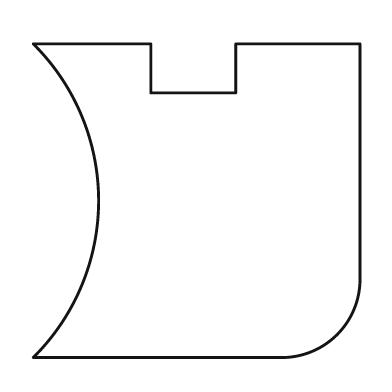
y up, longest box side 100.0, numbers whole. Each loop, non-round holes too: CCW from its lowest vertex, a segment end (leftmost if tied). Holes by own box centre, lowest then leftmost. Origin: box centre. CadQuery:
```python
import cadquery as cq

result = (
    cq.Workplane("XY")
    .moveTo(-50.0, -48.0)
    .lineTo(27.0, -48.0)
    .threePointArc((43.0, -41.0), (50.0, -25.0))
    .lineTo(50.0, 48.0)
    .lineTo(12.0, 48.0)
    .lineTo(12.0, 33.0)
    .lineTo(-14.0, 33.0)
    .lineTo(-14.0, 48.0)
    .lineTo(-50.0, 48.0)
    .threePointArc((-30.0, 0.0), (-50.0, -48.0))
    .close()
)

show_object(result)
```